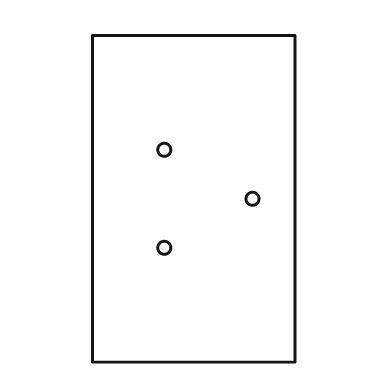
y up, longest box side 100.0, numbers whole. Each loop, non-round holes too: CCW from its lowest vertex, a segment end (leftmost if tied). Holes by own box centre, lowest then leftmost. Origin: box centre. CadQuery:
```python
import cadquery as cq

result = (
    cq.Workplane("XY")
    .moveTo(-31.0, -50.0)
    .lineTo(31.0, -50.0)
    .lineTo(31.0, 50.0)
    .lineTo(-31.0, 50.0)
    .close()
    .moveTo(-9.0, -15.0)
    .circle(2.0)
    .moveTo(18.0, 0.0)
    .circle(2.0)
    .moveTo(-9.0, 15.0)
    .circle(2.0)
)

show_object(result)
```